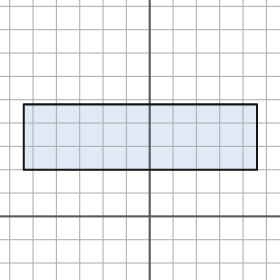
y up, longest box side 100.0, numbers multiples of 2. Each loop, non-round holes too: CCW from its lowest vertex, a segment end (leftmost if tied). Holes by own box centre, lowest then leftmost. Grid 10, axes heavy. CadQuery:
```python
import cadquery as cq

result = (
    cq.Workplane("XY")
    .moveTo(-54.0, 20.0)
    .lineTo(46.0, 20.0)
    .lineTo(46.0, 48.0)
    .lineTo(-54.0, 48.0)
    .close()
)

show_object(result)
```